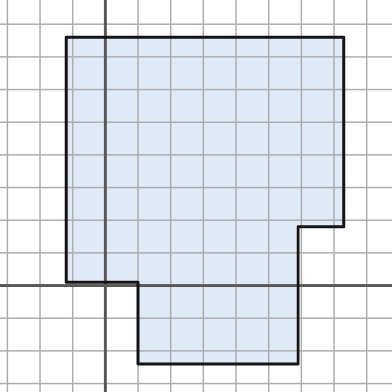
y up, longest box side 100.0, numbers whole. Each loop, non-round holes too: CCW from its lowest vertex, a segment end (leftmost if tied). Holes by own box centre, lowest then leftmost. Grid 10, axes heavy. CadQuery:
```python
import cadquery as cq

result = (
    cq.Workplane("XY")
    .moveTo(10.0, -24.0)
    .lineTo(59.0, -24.0)
    .lineTo(59.0, 18.0)
    .lineTo(73.0, 18.0)
    .lineTo(73.0, 76.0)
    .lineTo(-12.0, 76.0)
    .lineTo(-12.0, 1.0)
    .lineTo(10.0, 1.0)
    .close()
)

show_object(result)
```